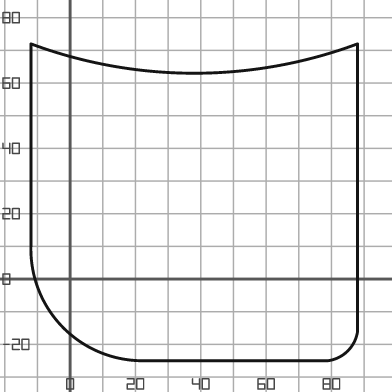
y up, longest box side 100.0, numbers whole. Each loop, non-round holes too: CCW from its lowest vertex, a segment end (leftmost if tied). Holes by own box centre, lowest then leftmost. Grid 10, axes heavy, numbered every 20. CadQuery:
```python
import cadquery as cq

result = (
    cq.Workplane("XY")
    .moveTo(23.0, -25.0)
    .lineTo(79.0, -25.0)
    .threePointArc((85.0, -22.0), (88.0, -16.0))
    .lineTo(88.0, 72.0)
    .threePointArc((38.0, 63.0), (-12.0, 72.0))
    .lineTo(-12.0, 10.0)
    .threePointArc((-2.0, -15.0), (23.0, -25.0))
    .close()
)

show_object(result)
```